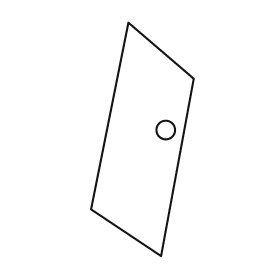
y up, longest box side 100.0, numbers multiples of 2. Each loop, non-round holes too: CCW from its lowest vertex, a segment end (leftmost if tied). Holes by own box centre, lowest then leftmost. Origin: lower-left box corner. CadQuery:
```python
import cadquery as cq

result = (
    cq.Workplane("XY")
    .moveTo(30.0, 0.0)
    .lineTo(44.0, 76.0)
    .lineTo(16.0, 100.0)
    .lineTo(0.0, 20.0)
    .close()
    .moveTo(32.0, 54.0)
    .circle(4.0)
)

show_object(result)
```